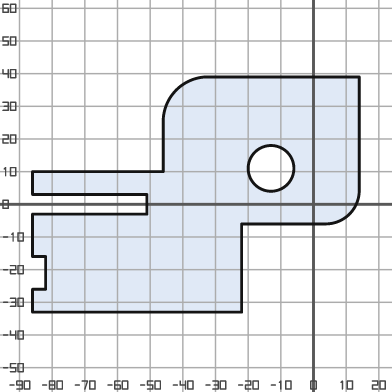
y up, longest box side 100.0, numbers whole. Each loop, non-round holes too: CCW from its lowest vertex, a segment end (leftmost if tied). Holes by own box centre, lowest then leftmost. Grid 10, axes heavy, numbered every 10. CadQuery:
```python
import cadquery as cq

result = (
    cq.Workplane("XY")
    .moveTo(-86.0, -33.0)
    .lineTo(-22.0, -33.0)
    .lineTo(-22.0, -6.0)
    .lineTo(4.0, -6.0)
    .threePointArc((11.0, -3.0), (14.0, 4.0))
    .lineTo(14.0, 39.0)
    .lineTo(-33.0, 39.0)
    .threePointArc((-42.0, 35.0), (-46.0, 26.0))
    .lineTo(-46.0, 10.0)
    .lineTo(-86.0, 10.0)
    .lineTo(-86.0, 3.0)
    .lineTo(-51.0, 3.0)
    .lineTo(-51.0, -3.0)
    .lineTo(-86.0, -3.0)
    .lineTo(-86.0, -16.0)
    .lineTo(-82.0, -16.0)
    .lineTo(-82.0, -26.0)
    .lineTo(-86.0, -26.0)
    .close()
    .moveTo(-13.0, 11.0)
    .circle(7.0)
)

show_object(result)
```